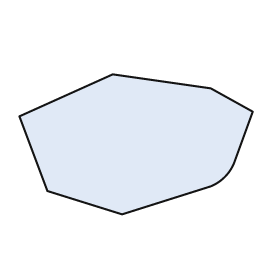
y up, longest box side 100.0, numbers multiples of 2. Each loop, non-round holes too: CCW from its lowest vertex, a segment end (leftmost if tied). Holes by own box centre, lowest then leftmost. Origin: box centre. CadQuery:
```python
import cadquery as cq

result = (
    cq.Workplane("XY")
    .moveTo(-6.0, -30.0)
    .lineTo(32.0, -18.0)
    .threePointArc((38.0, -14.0), (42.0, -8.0))
    .lineTo(50.0, 14.0)
    .lineTo(32.0, 24.0)
    .lineTo(-10.0, 30.0)
    .lineTo(-50.0, 12.0)
    .lineTo(-38.0, -20.0)
    .close()
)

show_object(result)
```